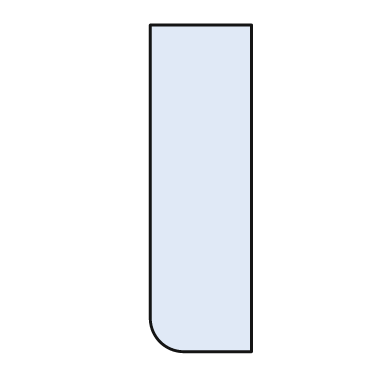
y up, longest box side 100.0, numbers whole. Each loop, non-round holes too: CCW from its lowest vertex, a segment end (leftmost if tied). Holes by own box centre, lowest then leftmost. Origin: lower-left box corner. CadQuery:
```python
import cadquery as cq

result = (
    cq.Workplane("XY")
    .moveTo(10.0, 0.0)
    .lineTo(31.0, 0.0)
    .lineTo(31.0, 100.0)
    .lineTo(0.0, 100.0)
    .lineTo(0.0, 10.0)
    .threePointArc((3.0, 3.0), (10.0, 0.0))
    .close()
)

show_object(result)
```